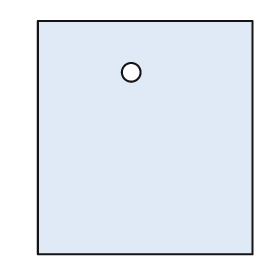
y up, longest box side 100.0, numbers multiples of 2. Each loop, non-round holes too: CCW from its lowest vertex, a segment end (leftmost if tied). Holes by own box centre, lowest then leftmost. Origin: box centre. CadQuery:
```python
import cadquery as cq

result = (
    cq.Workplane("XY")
    .moveTo(-46.0, -50.0)
    .lineTo(46.0, -50.0)
    .lineTo(46.0, 50.0)
    .lineTo(-46.0, 50.0)
    .close()
    .moveTo(-6.0, 28.0)
    .circle(4.0)
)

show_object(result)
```